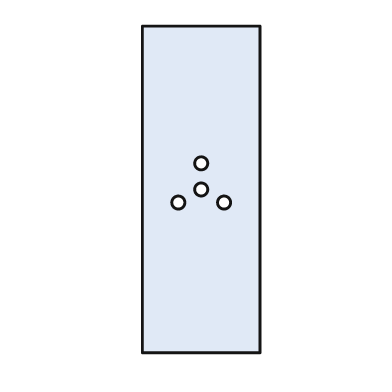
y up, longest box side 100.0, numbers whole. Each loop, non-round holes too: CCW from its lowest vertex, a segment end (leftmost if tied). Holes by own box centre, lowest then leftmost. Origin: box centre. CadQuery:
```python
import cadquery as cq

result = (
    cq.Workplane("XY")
    .moveTo(-18.0, -50.0)
    .lineTo(18.0, -50.0)
    .lineTo(18.0, 50.0)
    .lineTo(-18.0, 50.0)
    .close()
    .moveTo(-7.0, -4.0)
    .circle(2.0)
    .moveTo(7.0, -4.0)
    .circle(2.0)
    .moveTo(0.0, 0.0)
    .circle(2.0)
    .moveTo(0.0, 8.0)
    .circle(2.0)
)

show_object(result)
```